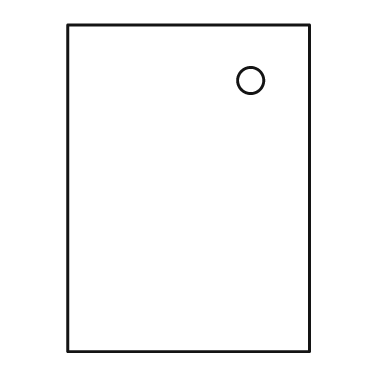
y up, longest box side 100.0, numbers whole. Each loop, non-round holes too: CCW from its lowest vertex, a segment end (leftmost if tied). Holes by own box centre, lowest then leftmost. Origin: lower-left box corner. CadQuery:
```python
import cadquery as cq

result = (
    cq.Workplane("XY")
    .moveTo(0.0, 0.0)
    .lineTo(74.0, 0.0)
    .lineTo(74.0, 100.0)
    .lineTo(0.0, 100.0)
    .close()
    .moveTo(56.0, 83.0)
    .circle(4.0)
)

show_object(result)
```